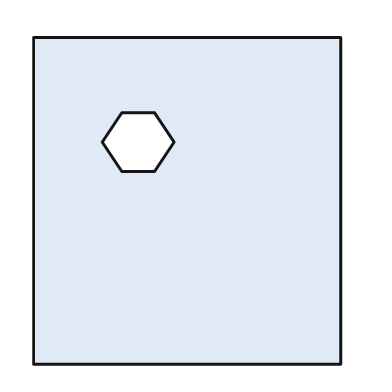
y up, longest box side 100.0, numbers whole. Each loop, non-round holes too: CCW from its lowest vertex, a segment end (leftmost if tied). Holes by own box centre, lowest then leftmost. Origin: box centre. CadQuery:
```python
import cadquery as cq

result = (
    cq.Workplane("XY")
    .moveTo(-47.0, -50.0)
    .lineTo(47.0, -50.0)
    .lineTo(47.0, 50.0)
    .lineTo(-47.0, 50.0)
    .close()
    .moveTo(-20.0, 9.0)
    .lineTo(-10.0, 9.0)
    .lineTo(-4.0, 18.0)
    .lineTo(-10.0, 27.0)
    .lineTo(-20.0, 27.0)
    .lineTo(-26.0, 18.0)
    .close()
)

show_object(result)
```